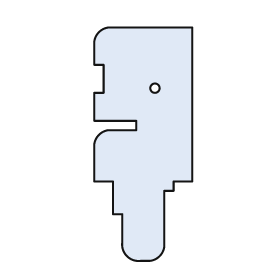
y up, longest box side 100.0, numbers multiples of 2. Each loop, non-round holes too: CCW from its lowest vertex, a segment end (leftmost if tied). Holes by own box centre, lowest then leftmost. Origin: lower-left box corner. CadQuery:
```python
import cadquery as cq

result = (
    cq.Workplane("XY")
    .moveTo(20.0, 0.0)
    .lineTo(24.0, 0.0)
    .threePointArc((28.0, 2.0), (30.0, 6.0))
    .lineTo(30.0, 30.0)
    .lineTo(34.0, 30.0)
    .lineTo(34.0, 34.0)
    .lineTo(42.0, 34.0)
    .lineTo(42.0, 100.0)
    .lineTo(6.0, 100.0)
    .threePointArc((2.0, 98.0), (0.0, 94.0))
    .lineTo(0.0, 84.0)
    .lineTo(4.0, 84.0)
    .lineTo(4.0, 72.0)
    .lineTo(0.0, 72.0)
    .lineTo(0.0, 60.0)
    .lineTo(18.0, 60.0)
    .lineTo(18.0, 56.0)
    .lineTo(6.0, 56.0)
    .threePointArc((2.0, 54.0), (0.0, 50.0))
    .lineTo(0.0, 34.0)
    .lineTo(8.0, 34.0)
    .lineTo(8.0, 20.0)
    .lineTo(12.0, 20.0)
    .lineTo(12.0, 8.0)
    .threePointArc((14.0, 2.0), (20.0, 0.0))
    .close()
    .moveTo(26.0, 74.0)
    .circle(2.0)
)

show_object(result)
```